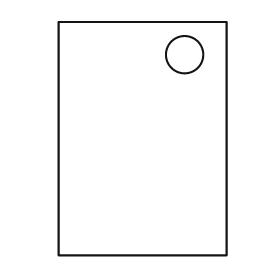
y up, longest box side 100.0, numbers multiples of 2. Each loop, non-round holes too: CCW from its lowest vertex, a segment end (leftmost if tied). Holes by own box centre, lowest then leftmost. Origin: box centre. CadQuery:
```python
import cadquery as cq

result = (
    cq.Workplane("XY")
    .moveTo(-36.0, -50.0)
    .lineTo(36.0, -50.0)
    .lineTo(36.0, 50.0)
    .lineTo(-36.0, 50.0)
    .close()
    .moveTo(18.0, 36.0)
    .circle(8.0)
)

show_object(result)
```